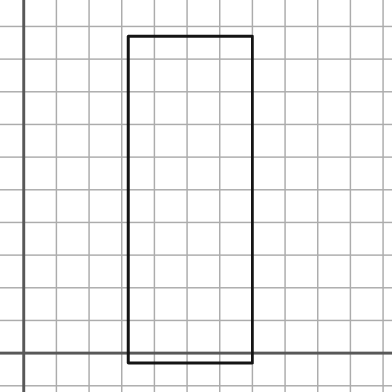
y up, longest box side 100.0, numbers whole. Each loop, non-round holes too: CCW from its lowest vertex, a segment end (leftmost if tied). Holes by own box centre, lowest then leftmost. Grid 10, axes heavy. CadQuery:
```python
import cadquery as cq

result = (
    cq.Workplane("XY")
    .moveTo(32.0, -3.0)
    .lineTo(70.0, -3.0)
    .lineTo(70.0, 97.0)
    .lineTo(32.0, 97.0)
    .close()
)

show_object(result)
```